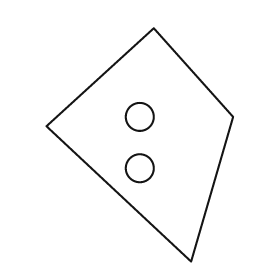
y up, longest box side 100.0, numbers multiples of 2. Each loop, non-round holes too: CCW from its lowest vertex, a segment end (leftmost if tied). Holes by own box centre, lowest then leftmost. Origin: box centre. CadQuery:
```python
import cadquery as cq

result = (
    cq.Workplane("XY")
    .moveTo(22.0, -50.0)
    .lineTo(40.0, 12.0)
    .lineTo(6.0, 50.0)
    .lineTo(-40.0, 8.0)
    .close()
    .moveTo(0.0, -10.0)
    .circle(6.0)
    .moveTo(0.0, 12.0)
    .circle(6.0)
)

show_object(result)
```